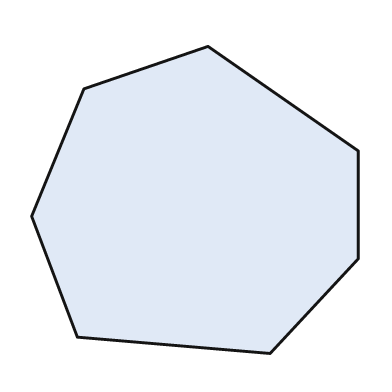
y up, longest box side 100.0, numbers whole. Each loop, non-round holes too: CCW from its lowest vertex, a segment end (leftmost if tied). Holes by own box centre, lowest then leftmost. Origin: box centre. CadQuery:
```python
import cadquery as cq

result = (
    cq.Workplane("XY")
    .moveTo(23.0, -47.0)
    .lineTo(50.0, -18.0)
    .lineTo(50.0, 15.0)
    .lineTo(4.0, 47.0)
    .lineTo(-34.0, 34.0)
    .lineTo(-50.0, -5.0)
    .lineTo(-36.0, -42.0)
    .close()
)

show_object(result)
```